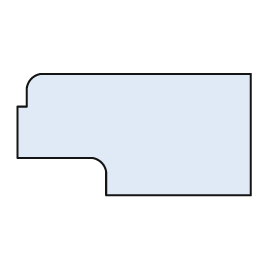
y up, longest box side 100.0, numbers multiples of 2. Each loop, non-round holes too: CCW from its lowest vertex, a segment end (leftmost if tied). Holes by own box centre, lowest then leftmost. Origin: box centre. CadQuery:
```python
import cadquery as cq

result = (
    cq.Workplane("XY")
    .moveTo(-12.0, -26.0)
    .lineTo(50.0, -26.0)
    .lineTo(50.0, 26.0)
    .lineTo(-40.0, 26.0)
    .threePointArc((-44.0, 24.0), (-46.0, 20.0))
    .lineTo(-46.0, 12.0)
    .lineTo(-50.0, 12.0)
    .lineTo(-50.0, -10.0)
    .lineTo(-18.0, -10.0)
    .threePointArc((-14.0, -12.0), (-12.0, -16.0))
    .close()
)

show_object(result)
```